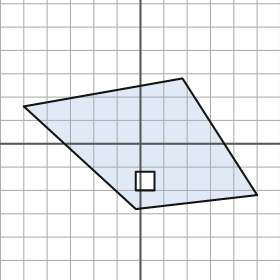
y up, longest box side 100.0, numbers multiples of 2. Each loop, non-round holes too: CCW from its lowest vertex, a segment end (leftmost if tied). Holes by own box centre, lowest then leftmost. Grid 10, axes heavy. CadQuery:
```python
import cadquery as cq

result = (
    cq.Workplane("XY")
    .moveTo(-2.0, -28.0)
    .lineTo(50.0, -22.0)
    .lineTo(18.0, 28.0)
    .lineTo(-50.0, 16.0)
    .close()
    .moveTo(-2.0, -20.0)
    .lineTo(6.0, -20.0)
    .lineTo(6.0, -12.0)
    .lineTo(-2.0, -12.0)
    .close()
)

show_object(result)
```